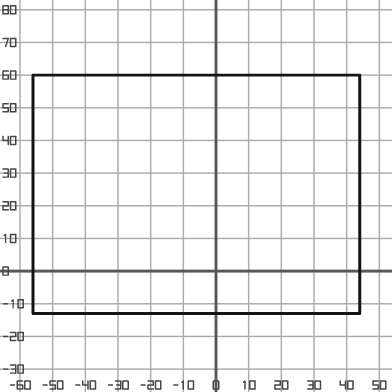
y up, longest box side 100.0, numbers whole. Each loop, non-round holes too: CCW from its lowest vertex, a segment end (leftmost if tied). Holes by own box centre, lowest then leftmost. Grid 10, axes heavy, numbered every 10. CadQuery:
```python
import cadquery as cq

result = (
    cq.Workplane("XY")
    .moveTo(-56.0, -13.0)
    .lineTo(44.0, -13.0)
    .lineTo(44.0, 60.0)
    .lineTo(-56.0, 60.0)
    .close()
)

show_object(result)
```